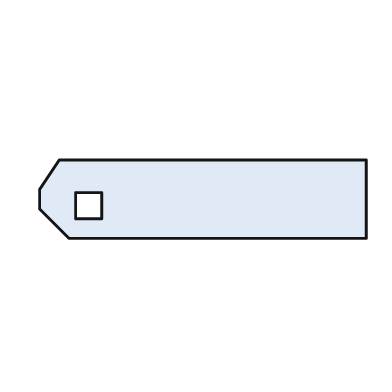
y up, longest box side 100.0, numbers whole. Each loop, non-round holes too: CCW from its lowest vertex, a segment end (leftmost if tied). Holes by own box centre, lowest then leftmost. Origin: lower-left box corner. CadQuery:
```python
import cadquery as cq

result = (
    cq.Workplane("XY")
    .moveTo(9.0, 0.0)
    .lineTo(100.0, 0.0)
    .lineTo(100.0, 24.0)
    .lineTo(6.0, 24.0)
    .lineTo(0.0, 15.0)
    .lineTo(0.0, 9.0)
    .close()
    .moveTo(11.0, 6.0)
    .lineTo(19.0, 6.0)
    .lineTo(19.0, 14.0)
    .lineTo(11.0, 14.0)
    .close()
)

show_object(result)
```